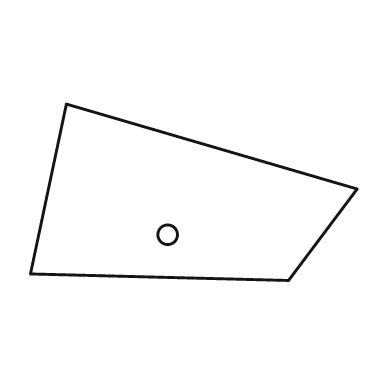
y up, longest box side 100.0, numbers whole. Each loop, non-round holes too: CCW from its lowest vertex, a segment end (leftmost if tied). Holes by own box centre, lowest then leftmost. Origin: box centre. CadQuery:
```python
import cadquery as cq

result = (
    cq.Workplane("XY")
    .moveTo(29.0, -27.0)
    .lineTo(50.0, 1.0)
    .lineTo(-39.0, 27.0)
    .lineTo(-50.0, -25.0)
    .close()
    .moveTo(-8.0, -13.0)
    .circle(3.0)
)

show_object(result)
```